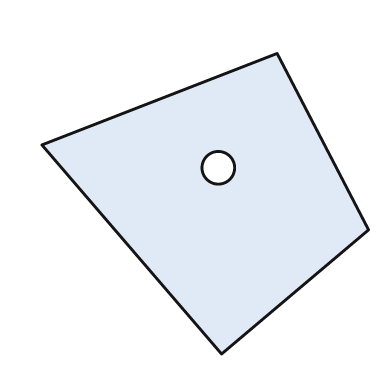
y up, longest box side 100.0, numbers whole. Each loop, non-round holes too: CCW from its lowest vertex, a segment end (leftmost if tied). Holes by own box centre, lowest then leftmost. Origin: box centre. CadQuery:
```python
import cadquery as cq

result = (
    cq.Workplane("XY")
    .moveTo(5.0, -46.0)
    .lineTo(50.0, -8.0)
    .lineTo(22.0, 46.0)
    .lineTo(-50.0, 18.0)
    .close()
    .moveTo(4.0, 11.0)
    .circle(5.0)
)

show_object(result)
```